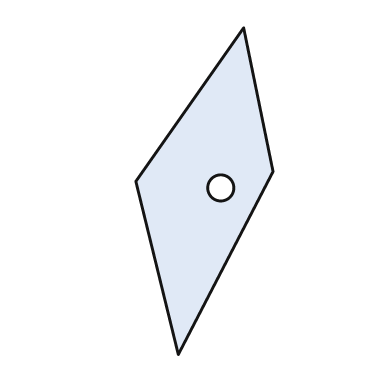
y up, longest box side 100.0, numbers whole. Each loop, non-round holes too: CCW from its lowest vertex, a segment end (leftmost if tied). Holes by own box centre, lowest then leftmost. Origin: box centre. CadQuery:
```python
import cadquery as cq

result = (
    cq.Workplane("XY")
    .moveTo(-8.0, -50.0)
    .lineTo(21.0, 6.0)
    .lineTo(12.0, 50.0)
    .lineTo(-21.0, 3.0)
    .close()
    .moveTo(5.0, 1.0)
    .circle(4.0)
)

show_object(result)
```